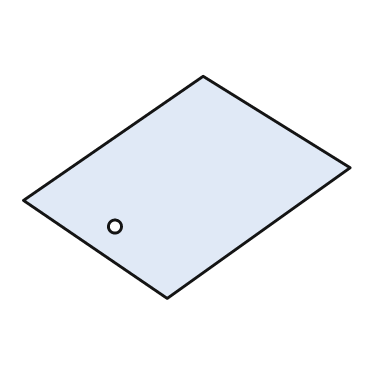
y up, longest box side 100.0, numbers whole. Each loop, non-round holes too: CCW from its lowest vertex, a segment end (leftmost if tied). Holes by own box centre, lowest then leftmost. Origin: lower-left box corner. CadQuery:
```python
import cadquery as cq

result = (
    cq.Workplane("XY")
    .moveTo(44.0, 0.0)
    .lineTo(100.0, 40.0)
    .lineTo(55.0, 68.0)
    .lineTo(0.0, 30.0)
    .close()
    .moveTo(28.0, 22.0)
    .circle(2.0)
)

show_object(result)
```